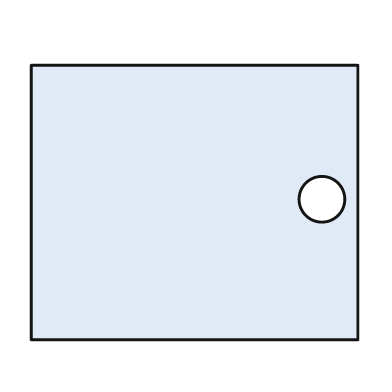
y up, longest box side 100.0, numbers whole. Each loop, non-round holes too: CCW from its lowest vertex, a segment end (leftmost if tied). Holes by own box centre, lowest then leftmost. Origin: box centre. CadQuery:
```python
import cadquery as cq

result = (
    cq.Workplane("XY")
    .moveTo(-50.0, -42.0)
    .lineTo(50.0, -42.0)
    .lineTo(50.0, 42.0)
    .lineTo(-50.0, 42.0)
    .close()
    .moveTo(39.0, 1.0)
    .circle(7.0)
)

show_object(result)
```